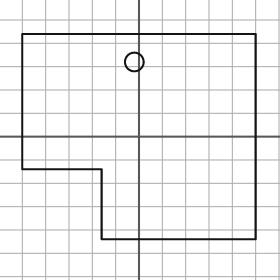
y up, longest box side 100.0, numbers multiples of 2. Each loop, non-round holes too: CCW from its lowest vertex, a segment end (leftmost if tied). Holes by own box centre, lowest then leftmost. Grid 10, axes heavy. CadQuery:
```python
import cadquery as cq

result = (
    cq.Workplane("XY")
    .moveTo(-16.0, -44.0)
    .lineTo(50.0, -44.0)
    .lineTo(50.0, 44.0)
    .lineTo(-50.0, 44.0)
    .lineTo(-50.0, -14.0)
    .lineTo(-16.0, -14.0)
    .close()
    .moveTo(-2.0, 32.0)
    .circle(4.0)
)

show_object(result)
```